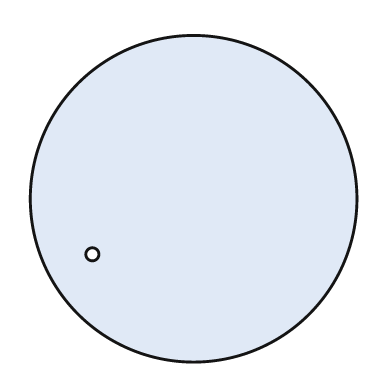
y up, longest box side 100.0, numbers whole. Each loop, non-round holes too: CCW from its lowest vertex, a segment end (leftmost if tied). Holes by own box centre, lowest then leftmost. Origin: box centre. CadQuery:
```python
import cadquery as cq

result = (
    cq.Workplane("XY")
    .moveTo(0.0, 0.0)
    .circle(50.0)
    .moveTo(-31.0, -17.0)
    .circle(2.0)
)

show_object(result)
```